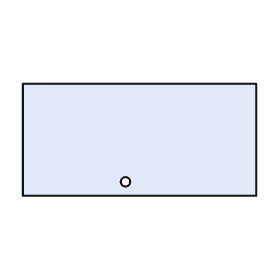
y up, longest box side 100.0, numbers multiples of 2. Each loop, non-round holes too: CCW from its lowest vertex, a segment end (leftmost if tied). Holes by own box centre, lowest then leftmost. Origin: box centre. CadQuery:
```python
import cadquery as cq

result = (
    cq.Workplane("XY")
    .moveTo(-50.0, -24.0)
    .lineTo(50.0, -24.0)
    .lineTo(50.0, 24.0)
    .lineTo(-50.0, 24.0)
    .close()
    .moveTo(-6.0, -18.0)
    .circle(2.0)
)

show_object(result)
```